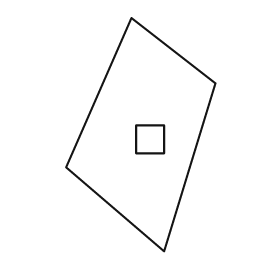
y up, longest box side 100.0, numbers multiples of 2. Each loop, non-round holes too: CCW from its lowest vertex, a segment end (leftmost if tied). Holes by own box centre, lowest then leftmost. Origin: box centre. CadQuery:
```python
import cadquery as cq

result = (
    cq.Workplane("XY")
    .moveTo(10.0, -50.0)
    .lineTo(32.0, 22.0)
    .lineTo(-4.0, 50.0)
    .lineTo(-32.0, -14.0)
    .close()
    .moveTo(-2.0, -8.0)
    .lineTo(10.0, -8.0)
    .lineTo(10.0, 4.0)
    .lineTo(-2.0, 4.0)
    .close()
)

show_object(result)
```